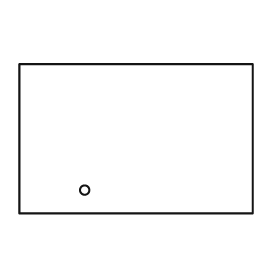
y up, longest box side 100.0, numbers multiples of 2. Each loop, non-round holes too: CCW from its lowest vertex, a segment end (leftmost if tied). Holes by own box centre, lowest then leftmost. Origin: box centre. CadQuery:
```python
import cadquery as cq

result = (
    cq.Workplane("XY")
    .moveTo(-50.0, -32.0)
    .lineTo(50.0, -32.0)
    .lineTo(50.0, 32.0)
    .lineTo(-50.0, 32.0)
    .close()
    .moveTo(-22.0, -22.0)
    .circle(2.0)
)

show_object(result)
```